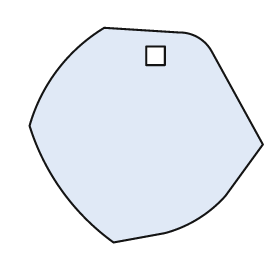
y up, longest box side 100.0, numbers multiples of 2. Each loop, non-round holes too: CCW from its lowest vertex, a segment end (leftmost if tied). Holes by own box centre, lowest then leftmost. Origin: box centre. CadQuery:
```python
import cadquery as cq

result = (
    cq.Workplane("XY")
    .moveTo(-14.0, -46.0)
    .lineTo(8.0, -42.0)
    .threePointArc((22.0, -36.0), (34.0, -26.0))
    .lineTo(50.0, -4.0)
    .lineTo(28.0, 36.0)
    .threePointArc((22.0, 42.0), (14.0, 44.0))
    .lineTo(-18.0, 46.0)
    .threePointArc((-38.0, 28.0), (-50.0, 4.0))
    .threePointArc((-36.0, -24.0), (-14.0, -46.0))
    .close()
    .moveTo(0.0, 30.0)
    .lineTo(8.0, 30.0)
    .lineTo(8.0, 38.0)
    .lineTo(0.0, 38.0)
    .close()
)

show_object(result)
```